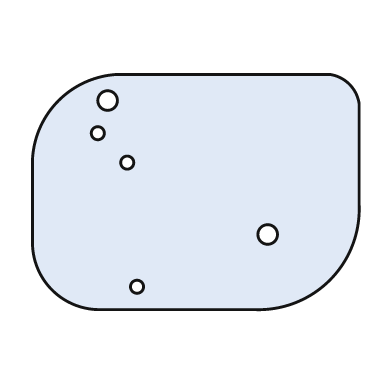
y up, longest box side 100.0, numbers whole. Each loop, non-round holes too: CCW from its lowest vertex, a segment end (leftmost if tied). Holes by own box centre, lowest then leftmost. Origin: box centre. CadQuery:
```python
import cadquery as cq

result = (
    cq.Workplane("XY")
    .moveTo(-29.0, -36.0)
    .lineTo(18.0, -36.0)
    .threePointArc((41.0, -27.0), (50.0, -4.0))
    .lineTo(50.0, 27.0)
    .threePointArc((47.0, 33.0), (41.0, 36.0))
    .lineTo(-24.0, 36.0)
    .threePointArc((-42.0, 28.0), (-50.0, 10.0))
    .lineTo(-50.0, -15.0)
    .threePointArc((-44.0, -30.0), (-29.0, -36.0))
    .close()
    .moveTo(-18.0, -29.0)
    .circle(2.0)
    .moveTo(22.0, -13.0)
    .circle(3.0)
    .moveTo(-21.0, 9.0)
    .circle(2.0)
    .moveTo(-30.0, 18.0)
    .circle(2.0)
    .moveTo(-27.0, 28.0)
    .circle(3.0)
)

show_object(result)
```